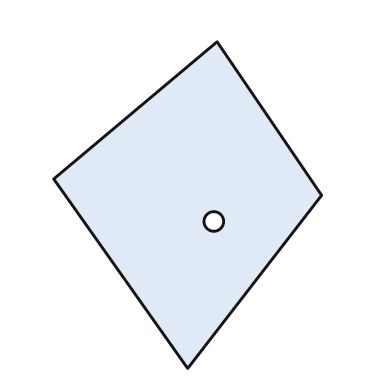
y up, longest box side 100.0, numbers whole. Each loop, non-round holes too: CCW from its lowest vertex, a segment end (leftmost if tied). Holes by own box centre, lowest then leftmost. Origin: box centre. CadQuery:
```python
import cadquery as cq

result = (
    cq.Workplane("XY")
    .moveTo(0.0, -50.0)
    .lineTo(41.0, 3.0)
    .lineTo(9.0, 50.0)
    .lineTo(-41.0, 8.0)
    .close()
    .moveTo(8.0, -5.0)
    .circle(3.0)
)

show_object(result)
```